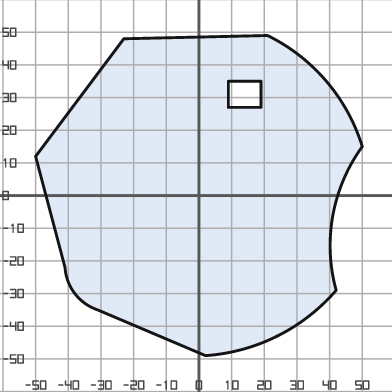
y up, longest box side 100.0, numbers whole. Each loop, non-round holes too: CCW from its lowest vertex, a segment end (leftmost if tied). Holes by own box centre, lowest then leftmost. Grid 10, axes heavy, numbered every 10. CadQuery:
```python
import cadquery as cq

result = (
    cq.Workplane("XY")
    .moveTo(2.0, -49.0)
    .threePointArc((24.0, -43.0), (42.0, -29.0))
    .threePointArc((41.0, -6.0), (50.0, 15.0))
    .threePointArc((39.0, 35.0), (21.0, 49.0))
    .lineTo(-23.0, 48.0)
    .lineTo(-50.0, 12.0)
    .lineTo(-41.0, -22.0)
    .threePointArc((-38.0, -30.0), (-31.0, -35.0))
    .close()
    .moveTo(9.0, 27.0)
    .lineTo(19.0, 27.0)
    .lineTo(19.0, 35.0)
    .lineTo(9.0, 35.0)
    .close()
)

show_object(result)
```